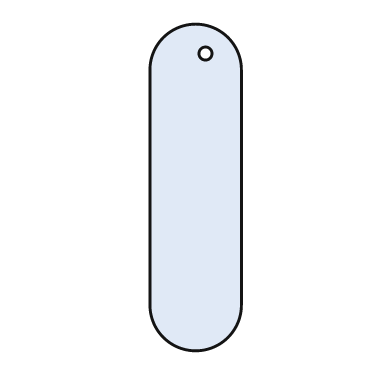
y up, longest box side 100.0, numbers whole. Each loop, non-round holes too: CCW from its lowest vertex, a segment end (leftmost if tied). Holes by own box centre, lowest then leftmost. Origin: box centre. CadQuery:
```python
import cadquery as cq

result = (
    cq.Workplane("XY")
    .moveTo(-14.0, -36.0)
    .threePointArc((0.0, -50.0), (14.0, -36.0))
    .lineTo(14.0, 36.0)
    .threePointArc((0.0, 50.0), (-14.0, 36.0))
    .close()
    .moveTo(3.0, 41.0)
    .circle(2.0)
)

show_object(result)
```